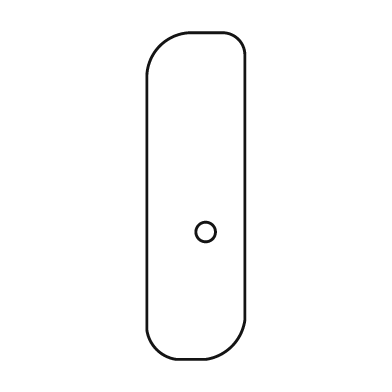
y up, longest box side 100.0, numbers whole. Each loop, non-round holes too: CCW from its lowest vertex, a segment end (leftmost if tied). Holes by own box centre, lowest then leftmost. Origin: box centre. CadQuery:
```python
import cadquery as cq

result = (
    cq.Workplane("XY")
    .moveTo(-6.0, -50.0)
    .lineTo(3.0, -50.0)
    .threePointArc((11.0, -46.0), (15.0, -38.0))
    .lineTo(15.0, 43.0)
    .threePointArc((13.0, 48.0), (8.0, 50.0))
    .lineTo(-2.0, 50.0)
    .threePointArc((-11.0, 46.0), (-15.0, 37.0))
    .lineTo(-15.0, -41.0)
    .threePointArc((-12.0, -47.0), (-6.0, -50.0))
    .close()
    .moveTo(3.0, -11.0)
    .circle(3.0)
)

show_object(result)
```